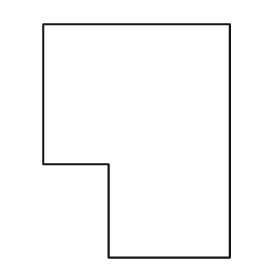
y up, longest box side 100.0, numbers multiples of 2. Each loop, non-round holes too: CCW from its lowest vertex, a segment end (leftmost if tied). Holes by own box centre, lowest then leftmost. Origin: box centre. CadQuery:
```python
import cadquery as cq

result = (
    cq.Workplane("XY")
    .moveTo(-12.0, -50.0)
    .lineTo(40.0, -50.0)
    .lineTo(40.0, 50.0)
    .lineTo(-40.0, 50.0)
    .lineTo(-40.0, -10.0)
    .lineTo(-12.0, -10.0)
    .close()
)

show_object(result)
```